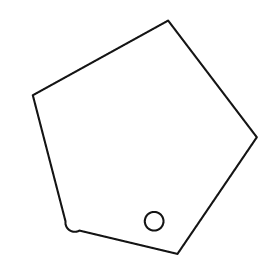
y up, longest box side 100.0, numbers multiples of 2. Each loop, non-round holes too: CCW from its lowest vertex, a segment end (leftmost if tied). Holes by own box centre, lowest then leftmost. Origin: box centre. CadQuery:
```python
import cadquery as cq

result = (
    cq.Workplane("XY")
    .moveTo(14.0, -50.0)
    .lineTo(48.0, 0.0)
    .lineTo(10.0, 50.0)
    .lineTo(-48.0, 18.0)
    .lineTo(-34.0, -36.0)
    .threePointArc((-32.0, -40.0), (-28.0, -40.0))
    .close()
    .moveTo(4.0, -36.0)
    .circle(4.0)
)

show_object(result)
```